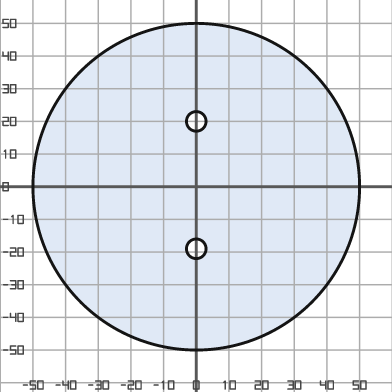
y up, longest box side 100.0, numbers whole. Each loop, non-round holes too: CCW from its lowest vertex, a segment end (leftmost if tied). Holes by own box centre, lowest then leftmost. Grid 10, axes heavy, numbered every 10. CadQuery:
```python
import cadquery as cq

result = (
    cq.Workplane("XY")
    .moveTo(0.0, 0.0)
    .circle(50.0)
    .moveTo(0.0, -19.0)
    .circle(3.0)
    .moveTo(0.0, 20.0)
    .circle(3.0)
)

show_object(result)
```